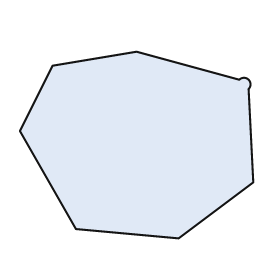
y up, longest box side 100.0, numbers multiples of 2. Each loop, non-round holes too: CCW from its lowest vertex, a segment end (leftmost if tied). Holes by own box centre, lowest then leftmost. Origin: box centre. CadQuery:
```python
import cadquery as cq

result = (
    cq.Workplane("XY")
    .moveTo(18.0, -40.0)
    .lineTo(50.0, -16.0)
    .lineTo(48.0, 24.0)
    .threePointArc((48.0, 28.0), (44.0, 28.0))
    .lineTo(0.0, 40.0)
    .lineTo(-36.0, 34.0)
    .lineTo(-50.0, 6.0)
    .lineTo(-26.0, -36.0)
    .close()
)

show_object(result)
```